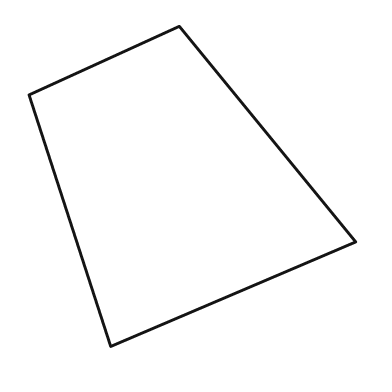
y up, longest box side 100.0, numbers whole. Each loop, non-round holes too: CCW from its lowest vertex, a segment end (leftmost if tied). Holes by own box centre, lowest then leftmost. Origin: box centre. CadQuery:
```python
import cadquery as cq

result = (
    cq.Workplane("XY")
    .moveTo(-25.0, -49.0)
    .lineTo(50.0, -17.0)
    .lineTo(-4.0, 49.0)
    .lineTo(-50.0, 28.0)
    .close()
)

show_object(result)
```